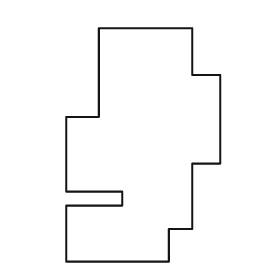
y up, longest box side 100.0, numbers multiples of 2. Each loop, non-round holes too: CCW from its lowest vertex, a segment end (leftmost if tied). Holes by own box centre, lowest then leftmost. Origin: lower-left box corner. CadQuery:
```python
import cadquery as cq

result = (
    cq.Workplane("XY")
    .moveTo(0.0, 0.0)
    .lineTo(44.0, 0.0)
    .lineTo(44.0, 14.0)
    .lineTo(54.0, 14.0)
    .lineTo(54.0, 42.0)
    .lineTo(66.0, 42.0)
    .lineTo(66.0, 80.0)
    .lineTo(54.0, 80.0)
    .lineTo(54.0, 100.0)
    .lineTo(14.0, 100.0)
    .lineTo(14.0, 62.0)
    .lineTo(0.0, 62.0)
    .lineTo(0.0, 30.0)
    .lineTo(24.0, 30.0)
    .lineTo(24.0, 24.0)
    .lineTo(0.0, 24.0)
    .close()
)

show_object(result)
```